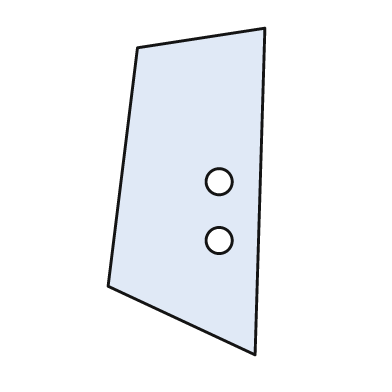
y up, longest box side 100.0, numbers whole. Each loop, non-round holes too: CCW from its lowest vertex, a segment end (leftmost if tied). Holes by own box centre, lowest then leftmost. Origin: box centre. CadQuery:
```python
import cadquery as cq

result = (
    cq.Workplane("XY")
    .moveTo(21.0, -50.0)
    .lineTo(24.0, 50.0)
    .lineTo(-15.0, 44.0)
    .lineTo(-24.0, -29.0)
    .close()
    .moveTo(10.0, -15.0)
    .circle(4.0)
    .moveTo(10.0, 3.0)
    .circle(4.0)
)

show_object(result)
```